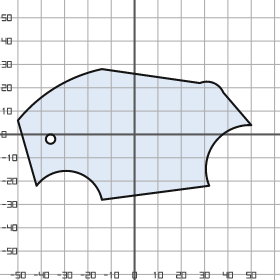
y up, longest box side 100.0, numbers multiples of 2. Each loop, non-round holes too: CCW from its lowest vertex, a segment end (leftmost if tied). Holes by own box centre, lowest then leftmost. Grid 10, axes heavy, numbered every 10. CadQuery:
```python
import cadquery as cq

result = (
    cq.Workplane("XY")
    .moveTo(-14.0, -28.0)
    .lineTo(32.0, -22.0)
    .threePointArc((34.0, -4.0), (50.0, 4.0))
    .lineTo(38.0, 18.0)
    .threePointArc((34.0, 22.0), (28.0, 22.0))
    .lineTo(-14.0, 28.0)
    .threePointArc((-34.0, 20.0), (-50.0, 6.0))
    .lineTo(-42.0, -22.0)
    .threePointArc((-26.0, -16.0), (-14.0, -28.0))
    .close()
    .moveTo(-36.0, -2.0)
    .circle(2.0)
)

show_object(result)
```